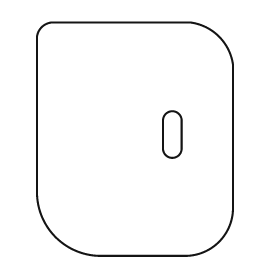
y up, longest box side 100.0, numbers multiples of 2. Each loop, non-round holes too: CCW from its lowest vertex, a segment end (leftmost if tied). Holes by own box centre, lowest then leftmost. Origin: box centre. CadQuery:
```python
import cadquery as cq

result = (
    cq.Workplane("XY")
    .moveTo(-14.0, -50.0)
    .lineTo(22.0, -50.0)
    .threePointArc((36.0, -44.0), (42.0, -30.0))
    .lineTo(42.0, 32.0)
    .threePointArc((36.0, 44.0), (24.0, 50.0))
    .lineTo(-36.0, 50.0)
    .threePointArc((-40.0, 48.0), (-42.0, 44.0))
    .lineTo(-42.0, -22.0)
    .threePointArc((-34.0, -42.0), (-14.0, -50.0))
    .close()
    .moveTo(12.0, -4.0)
    .threePointArc((16.0, -8.0), (20.0, -4.0))
    .lineTo(20.0, 8.0)
    .threePointArc((16.0, 12.0), (12.0, 8.0))
    .close()
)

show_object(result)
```